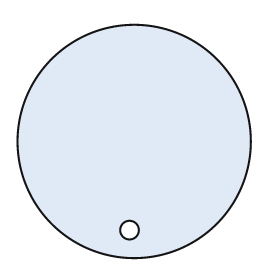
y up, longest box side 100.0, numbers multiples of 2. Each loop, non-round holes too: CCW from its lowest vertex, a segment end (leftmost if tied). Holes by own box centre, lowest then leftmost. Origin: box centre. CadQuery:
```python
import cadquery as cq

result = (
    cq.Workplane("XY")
    .moveTo(0.0, 0.0)
    .circle(50.0)
    .moveTo(-2.0, -38.0)
    .circle(4.0)
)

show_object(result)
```